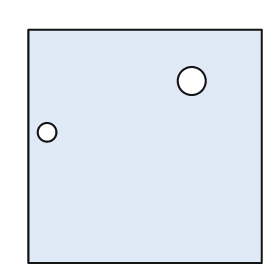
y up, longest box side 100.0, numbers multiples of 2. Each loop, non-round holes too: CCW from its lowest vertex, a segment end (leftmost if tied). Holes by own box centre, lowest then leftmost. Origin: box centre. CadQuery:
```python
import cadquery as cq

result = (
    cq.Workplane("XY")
    .moveTo(-50.0, -50.0)
    .lineTo(50.0, -50.0)
    .lineTo(50.0, 50.0)
    .lineTo(-50.0, 50.0)
    .close()
    .moveTo(-42.0, 6.0)
    .circle(4.0)
    .moveTo(20.0, 28.0)
    .circle(6.0)
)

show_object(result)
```